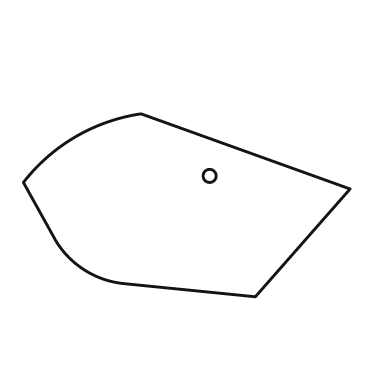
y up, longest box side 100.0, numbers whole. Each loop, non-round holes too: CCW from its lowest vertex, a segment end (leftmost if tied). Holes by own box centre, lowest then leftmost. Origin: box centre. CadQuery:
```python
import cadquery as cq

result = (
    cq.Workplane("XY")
    .moveTo(21.0, -28.0)
    .lineTo(50.0, 5.0)
    .lineTo(-14.0, 28.0)
    .threePointArc((-34.0, 21.0), (-50.0, 7.0))
    .lineTo(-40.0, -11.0)
    .threePointArc((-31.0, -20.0), (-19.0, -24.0))
    .close()
    .moveTo(7.0, 9.0)
    .circle(2.0)
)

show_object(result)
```